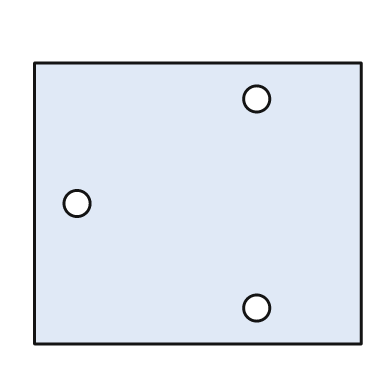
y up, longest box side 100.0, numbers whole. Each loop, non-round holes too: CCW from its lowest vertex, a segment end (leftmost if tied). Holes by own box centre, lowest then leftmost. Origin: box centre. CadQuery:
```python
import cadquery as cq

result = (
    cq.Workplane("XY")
    .moveTo(-50.0, -43.0)
    .lineTo(50.0, -43.0)
    .lineTo(50.0, 43.0)
    .lineTo(-50.0, 43.0)
    .close()
    .moveTo(18.0, -32.0)
    .circle(4.0)
    .moveTo(-37.0, 0.0)
    .circle(4.0)
    .moveTo(18.0, 32.0)
    .circle(4.0)
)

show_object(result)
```